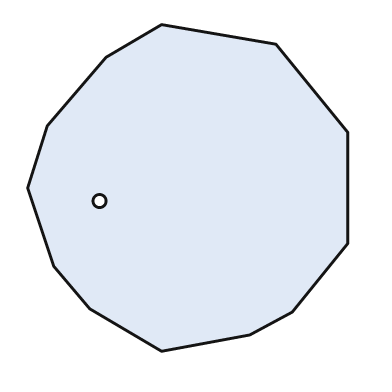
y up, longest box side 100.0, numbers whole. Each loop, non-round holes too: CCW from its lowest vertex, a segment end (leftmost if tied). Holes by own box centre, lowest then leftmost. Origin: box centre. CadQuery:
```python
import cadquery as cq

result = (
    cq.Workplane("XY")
    .moveTo(-8.0, -50.0)
    .lineTo(19.0, -45.0)
    .lineTo(32.0, -38.0)
    .lineTo(49.0, -17.0)
    .lineTo(49.0, 17.0)
    .lineTo(27.0, 44.0)
    .lineTo(-8.0, 50.0)
    .lineTo(-25.0, 40.0)
    .lineTo(-43.0, 19.0)
    .lineTo(-49.0, 0.0)
    .lineTo(-41.0, -24.0)
    .lineTo(-30.0, -37.0)
    .close()
    .moveTo(-27.0, -4.0)
    .circle(2.0)
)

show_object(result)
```